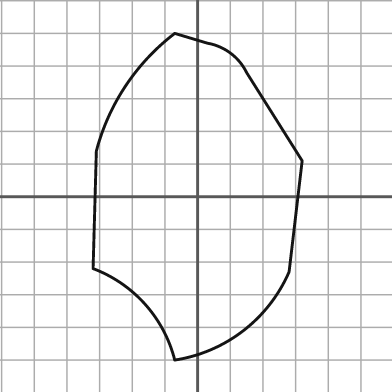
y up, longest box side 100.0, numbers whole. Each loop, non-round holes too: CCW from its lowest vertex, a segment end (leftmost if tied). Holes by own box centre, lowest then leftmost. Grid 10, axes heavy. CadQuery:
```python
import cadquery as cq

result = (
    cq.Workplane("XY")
    .moveTo(-7.0, -50.0)
    .threePointArc((14.0, -41.0), (28.0, -23.0))
    .lineTo(32.0, 11.0)
    .lineTo(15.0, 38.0)
    .threePointArc((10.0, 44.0), (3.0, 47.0))
    .lineTo(-7.0, 50.0)
    .threePointArc((-22.0, 34.0), (-31.0, 14.0))
    .lineTo(-32.0, -22.0)
    .threePointArc((-16.0, -33.0), (-7.0, -50.0))
    .close()
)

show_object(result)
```